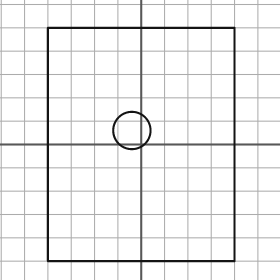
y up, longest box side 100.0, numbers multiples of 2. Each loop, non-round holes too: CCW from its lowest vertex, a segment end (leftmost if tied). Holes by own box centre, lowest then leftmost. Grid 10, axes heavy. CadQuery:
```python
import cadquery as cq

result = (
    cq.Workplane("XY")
    .moveTo(-40.0, -50.0)
    .lineTo(40.0, -50.0)
    .lineTo(40.0, 50.0)
    .lineTo(-40.0, 50.0)
    .close()
    .moveTo(-4.0, 6.0)
    .circle(8.0)
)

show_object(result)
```